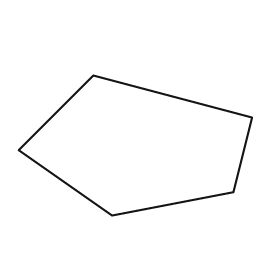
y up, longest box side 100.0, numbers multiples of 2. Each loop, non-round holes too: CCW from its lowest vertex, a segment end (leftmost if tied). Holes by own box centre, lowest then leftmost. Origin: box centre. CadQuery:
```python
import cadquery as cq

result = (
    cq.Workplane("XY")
    .moveTo(-10.0, -30.0)
    .lineTo(42.0, -20.0)
    .lineTo(50.0, 12.0)
    .lineTo(-18.0, 30.0)
    .lineTo(-50.0, -2.0)
    .close()
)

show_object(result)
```